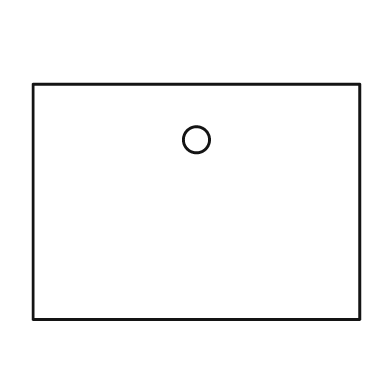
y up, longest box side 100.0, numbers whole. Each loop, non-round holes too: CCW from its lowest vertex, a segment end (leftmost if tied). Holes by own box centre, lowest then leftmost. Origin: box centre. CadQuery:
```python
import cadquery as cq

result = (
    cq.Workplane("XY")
    .moveTo(-50.0, -36.0)
    .lineTo(50.0, -36.0)
    .lineTo(50.0, 36.0)
    .lineTo(-50.0, 36.0)
    .close()
    .moveTo(0.0, 19.0)
    .circle(4.0)
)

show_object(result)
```